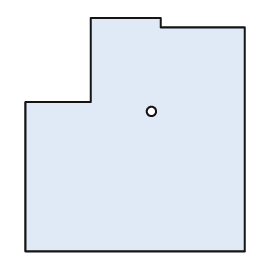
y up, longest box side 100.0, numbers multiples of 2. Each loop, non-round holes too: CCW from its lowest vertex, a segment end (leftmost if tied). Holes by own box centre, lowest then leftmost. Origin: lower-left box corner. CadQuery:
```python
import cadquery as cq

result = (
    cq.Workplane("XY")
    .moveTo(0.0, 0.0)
    .lineTo(94.0, 0.0)
    .lineTo(94.0, 96.0)
    .lineTo(58.0, 96.0)
    .lineTo(58.0, 100.0)
    .lineTo(28.0, 100.0)
    .lineTo(28.0, 64.0)
    .lineTo(0.0, 64.0)
    .close()
    .moveTo(54.0, 60.0)
    .circle(2.0)
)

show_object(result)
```